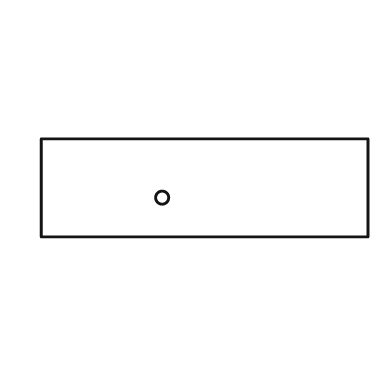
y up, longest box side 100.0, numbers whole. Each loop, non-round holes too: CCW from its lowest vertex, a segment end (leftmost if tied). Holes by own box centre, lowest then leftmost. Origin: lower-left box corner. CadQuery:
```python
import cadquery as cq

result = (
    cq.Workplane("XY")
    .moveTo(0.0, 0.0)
    .lineTo(100.0, 0.0)
    .lineTo(100.0, 30.0)
    .lineTo(0.0, 30.0)
    .close()
    .moveTo(37.0, 12.0)
    .circle(2.0)
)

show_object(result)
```